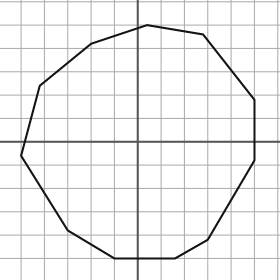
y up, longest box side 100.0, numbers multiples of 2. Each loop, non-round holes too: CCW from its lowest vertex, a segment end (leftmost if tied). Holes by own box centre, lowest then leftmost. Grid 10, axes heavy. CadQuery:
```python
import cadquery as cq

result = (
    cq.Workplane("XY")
    .moveTo(-10.0, -50.0)
    .lineTo(16.0, -50.0)
    .lineTo(30.0, -42.0)
    .lineTo(50.0, -8.0)
    .lineTo(50.0, 18.0)
    .lineTo(28.0, 46.0)
    .lineTo(4.0, 50.0)
    .lineTo(-20.0, 42.0)
    .lineTo(-42.0, 24.0)
    .lineTo(-50.0, -6.0)
    .lineTo(-30.0, -38.0)
    .close()
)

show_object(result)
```